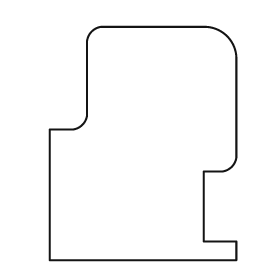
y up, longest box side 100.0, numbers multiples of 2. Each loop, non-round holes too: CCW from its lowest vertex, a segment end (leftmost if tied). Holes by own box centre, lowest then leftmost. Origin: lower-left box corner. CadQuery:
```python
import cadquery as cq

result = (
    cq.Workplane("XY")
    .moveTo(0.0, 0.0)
    .lineTo(80.0, 0.0)
    .lineTo(80.0, 8.0)
    .lineTo(66.0, 8.0)
    .lineTo(66.0, 38.0)
    .lineTo(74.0, 38.0)
    .threePointArc((78.0, 40.0), (80.0, 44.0))
    .lineTo(80.0, 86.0)
    .threePointArc((76.0, 96.0), (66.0, 100.0))
    .lineTo(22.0, 100.0)
    .threePointArc((18.0, 98.0), (16.0, 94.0))
    .lineTo(16.0, 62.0)
    .threePointArc((14.0, 58.0), (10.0, 56.0))
    .lineTo(0.0, 56.0)
    .close()
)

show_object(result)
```